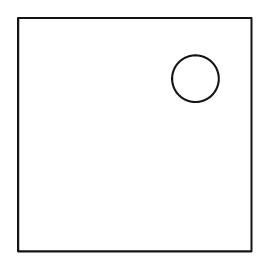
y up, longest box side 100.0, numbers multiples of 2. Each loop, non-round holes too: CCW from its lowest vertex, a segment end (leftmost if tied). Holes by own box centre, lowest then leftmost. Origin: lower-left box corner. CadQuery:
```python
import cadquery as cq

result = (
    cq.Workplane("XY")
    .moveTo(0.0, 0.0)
    .lineTo(100.0, 0.0)
    .lineTo(100.0, 100.0)
    .lineTo(0.0, 100.0)
    .close()
    .moveTo(76.0, 74.0)
    .circle(10.0)
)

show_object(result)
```